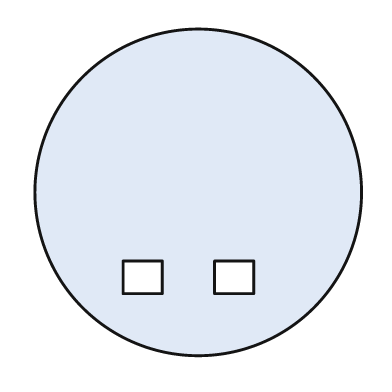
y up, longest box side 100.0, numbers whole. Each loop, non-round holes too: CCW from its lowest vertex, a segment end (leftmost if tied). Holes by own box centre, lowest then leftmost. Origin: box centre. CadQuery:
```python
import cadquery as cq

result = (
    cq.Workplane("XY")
    .moveTo(0.0, 0.0)
    .circle(50.0)
    .moveTo(-23.0, -31.0)
    .lineTo(-11.0, -31.0)
    .lineTo(-11.0, -21.0)
    .lineTo(-23.0, -21.0)
    .close()
    .moveTo(5.0, -31.0)
    .lineTo(17.0, -31.0)
    .lineTo(17.0, -21.0)
    .lineTo(5.0, -21.0)
    .close()
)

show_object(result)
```